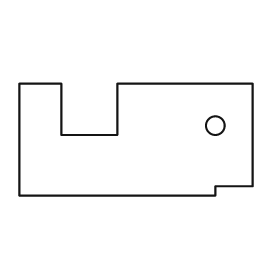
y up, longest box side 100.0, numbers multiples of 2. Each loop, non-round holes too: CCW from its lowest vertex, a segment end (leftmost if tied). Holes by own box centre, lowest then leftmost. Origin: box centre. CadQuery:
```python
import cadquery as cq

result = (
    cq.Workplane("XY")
    .moveTo(-50.0, -24.0)
    .lineTo(34.0, -24.0)
    .lineTo(34.0, -20.0)
    .lineTo(50.0, -20.0)
    .lineTo(50.0, 24.0)
    .lineTo(-8.0, 24.0)
    .lineTo(-8.0, 2.0)
    .lineTo(-32.0, 2.0)
    .lineTo(-32.0, 24.0)
    .lineTo(-50.0, 24.0)
    .close()
    .moveTo(34.0, 6.0)
    .circle(4.0)
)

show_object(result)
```